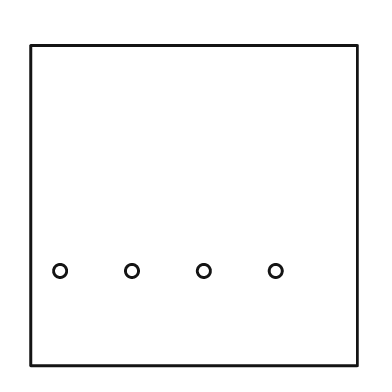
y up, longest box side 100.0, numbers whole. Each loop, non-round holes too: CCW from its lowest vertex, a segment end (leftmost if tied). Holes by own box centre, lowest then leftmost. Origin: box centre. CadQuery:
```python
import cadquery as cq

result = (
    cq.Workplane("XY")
    .moveTo(-50.0, -49.0)
    .lineTo(50.0, -49.0)
    .lineTo(50.0, 49.0)
    .lineTo(-50.0, 49.0)
    .close()
    .moveTo(-41.0, -20.0)
    .circle(2.0)
    .moveTo(-19.0, -20.0)
    .circle(2.0)
    .moveTo(3.0, -20.0)
    .circle(2.0)
    .moveTo(25.0, -20.0)
    .circle(2.0)
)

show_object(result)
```